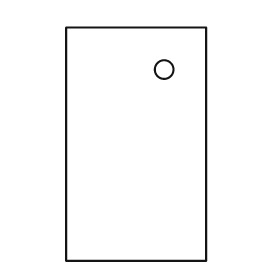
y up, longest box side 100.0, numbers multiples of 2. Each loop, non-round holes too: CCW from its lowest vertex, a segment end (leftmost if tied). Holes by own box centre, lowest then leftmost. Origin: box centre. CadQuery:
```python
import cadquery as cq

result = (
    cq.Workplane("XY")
    .moveTo(-30.0, -50.0)
    .lineTo(30.0, -50.0)
    .lineTo(30.0, 50.0)
    .lineTo(-30.0, 50.0)
    .close()
    .moveTo(12.0, 32.0)
    .circle(4.0)
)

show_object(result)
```